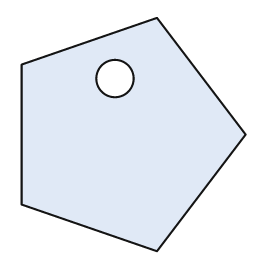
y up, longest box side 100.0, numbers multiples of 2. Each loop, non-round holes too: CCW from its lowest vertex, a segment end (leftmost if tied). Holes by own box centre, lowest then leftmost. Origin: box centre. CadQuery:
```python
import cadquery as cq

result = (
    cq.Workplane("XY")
    .moveTo(10.0, -50.0)
    .lineTo(48.0, 0.0)
    .lineTo(10.0, 50.0)
    .lineTo(-48.0, 30.0)
    .lineTo(-48.0, -30.0)
    .close()
    .moveTo(-8.0, 24.0)
    .circle(8.0)
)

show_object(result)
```